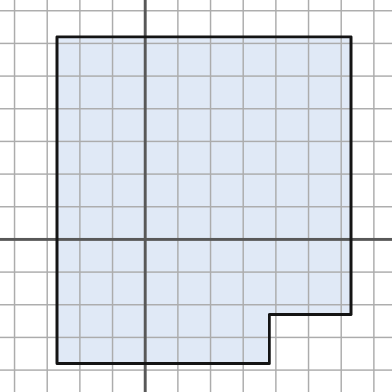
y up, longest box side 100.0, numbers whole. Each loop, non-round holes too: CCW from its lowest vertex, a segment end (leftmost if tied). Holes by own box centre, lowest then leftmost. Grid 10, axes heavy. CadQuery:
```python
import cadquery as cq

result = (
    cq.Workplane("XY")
    .moveTo(-27.0, -38.0)
    .lineTo(38.0, -38.0)
    .lineTo(38.0, -23.0)
    .lineTo(63.0, -23.0)
    .lineTo(63.0, 62.0)
    .lineTo(-27.0, 62.0)
    .close()
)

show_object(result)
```